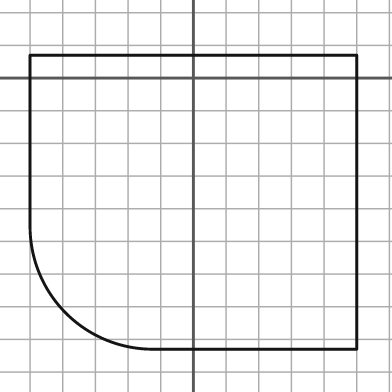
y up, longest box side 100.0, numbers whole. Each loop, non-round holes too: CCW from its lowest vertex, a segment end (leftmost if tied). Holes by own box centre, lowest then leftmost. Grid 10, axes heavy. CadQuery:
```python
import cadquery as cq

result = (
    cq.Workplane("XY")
    .moveTo(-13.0, -83.0)
    .lineTo(50.0, -83.0)
    .lineTo(50.0, 7.0)
    .lineTo(-50.0, 7.0)
    .lineTo(-50.0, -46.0)
    .threePointArc((-39.0, -72.0), (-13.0, -83.0))
    .close()
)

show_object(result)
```